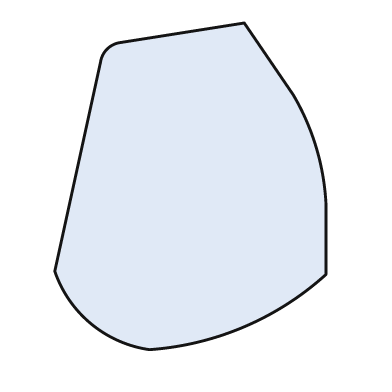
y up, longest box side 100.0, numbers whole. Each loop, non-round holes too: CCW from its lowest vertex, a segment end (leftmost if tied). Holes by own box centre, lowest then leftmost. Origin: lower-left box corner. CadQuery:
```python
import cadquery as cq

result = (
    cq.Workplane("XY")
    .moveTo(29.0, 0.0)
    .threePointArc((58.0, 7.0), (83.0, 23.0))
    .lineTo(83.0, 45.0)
    .threePointArc((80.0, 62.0), (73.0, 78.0))
    .lineTo(58.0, 100.0)
    .lineTo(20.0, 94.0)
    .threePointArc((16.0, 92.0), (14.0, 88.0))
    .lineTo(0.0, 24.0)
    .threePointArc((11.0, 8.0), (29.0, 0.0))
    .close()
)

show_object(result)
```